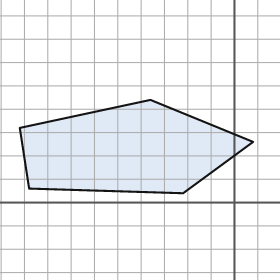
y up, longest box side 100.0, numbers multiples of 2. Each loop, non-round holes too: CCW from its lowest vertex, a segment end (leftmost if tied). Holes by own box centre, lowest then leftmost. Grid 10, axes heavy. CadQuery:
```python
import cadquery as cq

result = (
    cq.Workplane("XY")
    .moveTo(-22.0, 4.0)
    .lineTo(8.0, 26.0)
    .lineTo(-36.0, 44.0)
    .lineTo(-92.0, 32.0)
    .lineTo(-88.0, 6.0)
    .close()
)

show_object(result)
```